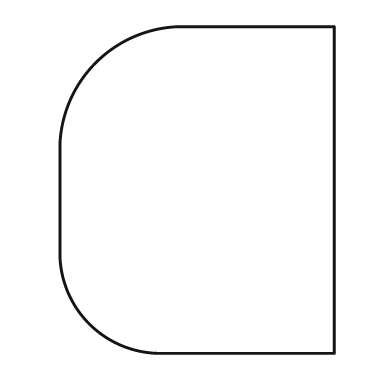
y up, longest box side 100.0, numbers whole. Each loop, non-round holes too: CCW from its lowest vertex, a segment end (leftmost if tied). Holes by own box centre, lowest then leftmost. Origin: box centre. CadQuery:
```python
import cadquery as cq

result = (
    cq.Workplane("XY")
    .moveTo(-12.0, -50.0)
    .lineTo(42.0, -50.0)
    .lineTo(42.0, 50.0)
    .lineTo(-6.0, 50.0)
    .threePointArc((-31.0, 39.0), (-42.0, 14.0))
    .lineTo(-42.0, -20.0)
    .threePointArc((-33.0, -41.0), (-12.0, -50.0))
    .close()
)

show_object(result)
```